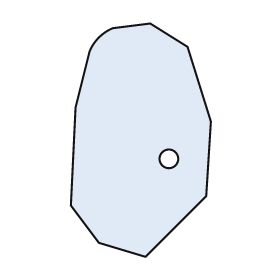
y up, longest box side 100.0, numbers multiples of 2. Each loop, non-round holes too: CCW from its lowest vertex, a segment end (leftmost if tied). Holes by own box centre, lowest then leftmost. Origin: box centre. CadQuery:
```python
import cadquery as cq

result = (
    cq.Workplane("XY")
    .moveTo(2.0, -50.0)
    .lineTo(28.0, -24.0)
    .lineTo(30.0, 8.0)
    .lineTo(20.0, 40.0)
    .lineTo(4.0, 50.0)
    .lineTo(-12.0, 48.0)
    .threePointArc((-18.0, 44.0), (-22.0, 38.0))
    .lineTo(-28.0, 14.0)
    .lineTo(-30.0, -28.0)
    .lineTo(-18.0, -44.0)
    .close()
    .moveTo(12.0, -8.0)
    .circle(4.0)
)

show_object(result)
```